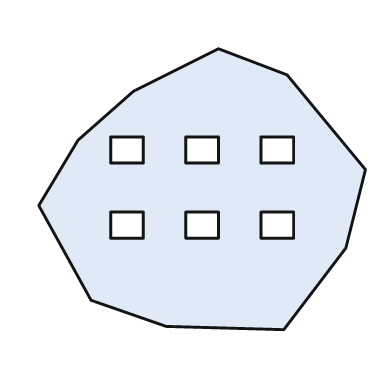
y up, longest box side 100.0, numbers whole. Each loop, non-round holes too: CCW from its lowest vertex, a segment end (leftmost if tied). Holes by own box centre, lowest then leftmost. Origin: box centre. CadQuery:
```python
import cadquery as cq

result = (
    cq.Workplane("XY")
    .moveTo(25.0, -43.0)
    .lineTo(44.0, -18.0)
    .lineTo(50.0, 6.0)
    .lineTo(26.0, 35.0)
    .lineTo(5.0, 43.0)
    .lineTo(-21.0, 30.0)
    .lineTo(-38.0, 15.0)
    .lineTo(-50.0, -5.0)
    .lineTo(-34.0, -34.0)
    .lineTo(-11.0, -42.0)
    .close()
    .moveTo(-28.0, -15.0)
    .lineTo(-18.0, -15.0)
    .lineTo(-18.0, -7.0)
    .lineTo(-28.0, -7.0)
    .close()
    .moveTo(-5.0, -15.0)
    .lineTo(5.0, -15.0)
    .lineTo(5.0, -7.0)
    .lineTo(-5.0, -7.0)
    .close()
    .moveTo(18.0, -15.0)
    .lineTo(28.0, -15.0)
    .lineTo(28.0, -7.0)
    .lineTo(18.0, -7.0)
    .close()
    .moveTo(-28.0, 8.0)
    .lineTo(-18.0, 8.0)
    .lineTo(-18.0, 16.0)
    .lineTo(-28.0, 16.0)
    .close()
    .moveTo(-5.0, 8.0)
    .lineTo(5.0, 8.0)
    .lineTo(5.0, 16.0)
    .lineTo(-5.0, 16.0)
    .close()
    .moveTo(18.0, 8.0)
    .lineTo(28.0, 8.0)
    .lineTo(28.0, 16.0)
    .lineTo(18.0, 16.0)
    .close()
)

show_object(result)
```